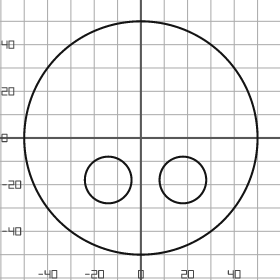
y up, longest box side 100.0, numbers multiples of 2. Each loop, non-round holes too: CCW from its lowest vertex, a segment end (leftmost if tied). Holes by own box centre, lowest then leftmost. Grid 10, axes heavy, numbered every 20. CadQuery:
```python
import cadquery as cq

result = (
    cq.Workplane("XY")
    .moveTo(0.0, 0.0)
    .circle(50.0)
    .moveTo(-14.0, -18.0)
    .circle(10.0)
    .moveTo(18.0, -18.0)
    .circle(10.0)
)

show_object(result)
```